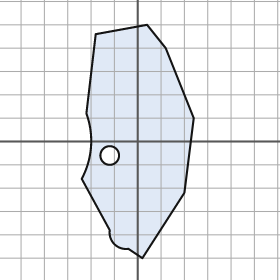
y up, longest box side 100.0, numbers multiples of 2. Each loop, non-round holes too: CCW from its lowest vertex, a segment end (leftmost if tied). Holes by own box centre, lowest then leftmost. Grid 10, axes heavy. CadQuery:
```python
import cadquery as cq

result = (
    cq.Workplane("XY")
    .moveTo(2.0, -50.0)
    .lineTo(20.0, -22.0)
    .lineTo(24.0, 10.0)
    .lineTo(12.0, 40.0)
    .lineTo(4.0, 50.0)
    .lineTo(-18.0, 46.0)
    .lineTo(-22.0, 12.0)
    .threePointArc((-20.0, -2.0), (-24.0, -16.0))
    .lineTo(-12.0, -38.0)
    .threePointArc((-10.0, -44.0), (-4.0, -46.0))
    .close()
    .moveTo(-12.0, -6.0)
    .circle(4.0)
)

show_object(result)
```